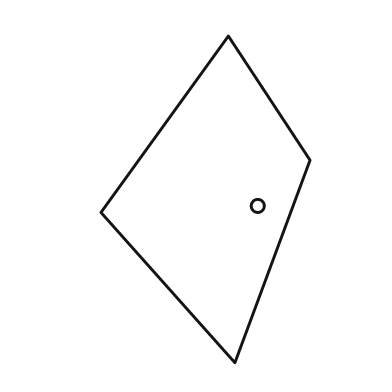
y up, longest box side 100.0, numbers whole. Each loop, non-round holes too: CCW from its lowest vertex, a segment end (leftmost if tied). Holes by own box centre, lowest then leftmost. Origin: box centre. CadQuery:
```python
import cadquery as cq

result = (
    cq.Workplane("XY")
    .moveTo(9.0, -50.0)
    .lineTo(32.0, 12.0)
    .lineTo(7.0, 50.0)
    .lineTo(-32.0, -4.0)
    .close()
    .moveTo(16.0, -2.0)
    .circle(2.0)
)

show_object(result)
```